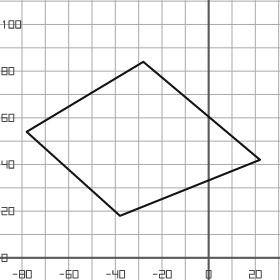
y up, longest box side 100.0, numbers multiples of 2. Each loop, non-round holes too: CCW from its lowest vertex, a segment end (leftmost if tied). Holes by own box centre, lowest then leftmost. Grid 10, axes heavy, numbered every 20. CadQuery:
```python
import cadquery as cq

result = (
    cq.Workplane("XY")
    .moveTo(-38.0, 18.0)
    .lineTo(22.0, 42.0)
    .lineTo(-28.0, 84.0)
    .lineTo(-78.0, 54.0)
    .close()
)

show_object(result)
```